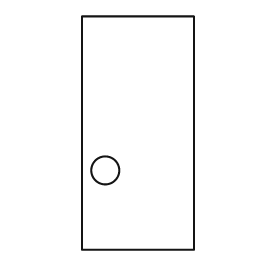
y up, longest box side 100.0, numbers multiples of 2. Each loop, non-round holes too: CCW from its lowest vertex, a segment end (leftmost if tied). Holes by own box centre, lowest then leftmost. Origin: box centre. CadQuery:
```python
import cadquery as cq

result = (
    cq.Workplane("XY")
    .moveTo(-24.0, -50.0)
    .lineTo(24.0, -50.0)
    .lineTo(24.0, 50.0)
    .lineTo(-24.0, 50.0)
    .close()
    .moveTo(-14.0, -16.0)
    .circle(6.0)
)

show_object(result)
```